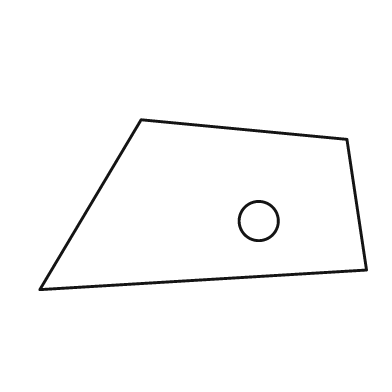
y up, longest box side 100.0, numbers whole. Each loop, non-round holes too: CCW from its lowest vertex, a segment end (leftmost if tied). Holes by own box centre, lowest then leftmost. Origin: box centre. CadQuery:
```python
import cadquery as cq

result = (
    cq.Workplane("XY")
    .moveTo(-50.0, -26.0)
    .lineTo(50.0, -20.0)
    .lineTo(44.0, 20.0)
    .lineTo(-19.0, 26.0)
    .close()
    .moveTo(17.0, -5.0)
    .circle(6.0)
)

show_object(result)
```